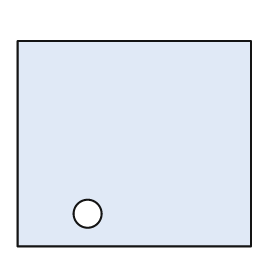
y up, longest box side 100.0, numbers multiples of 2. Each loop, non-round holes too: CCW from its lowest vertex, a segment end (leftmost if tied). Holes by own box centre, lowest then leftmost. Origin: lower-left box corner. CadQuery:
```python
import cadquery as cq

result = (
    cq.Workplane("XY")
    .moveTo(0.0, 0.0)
    .lineTo(100.0, 0.0)
    .lineTo(100.0, 88.0)
    .lineTo(0.0, 88.0)
    .close()
    .moveTo(30.0, 14.0)
    .circle(6.0)
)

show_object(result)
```